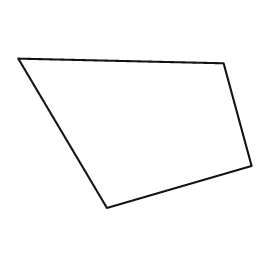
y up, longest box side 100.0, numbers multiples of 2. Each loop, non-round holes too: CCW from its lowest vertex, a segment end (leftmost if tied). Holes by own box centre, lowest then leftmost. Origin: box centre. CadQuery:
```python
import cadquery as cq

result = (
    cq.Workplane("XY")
    .moveTo(-12.0, -32.0)
    .lineTo(50.0, -14.0)
    .lineTo(38.0, 30.0)
    .lineTo(-50.0, 32.0)
    .close()
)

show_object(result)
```